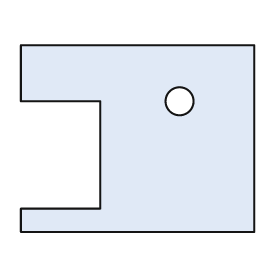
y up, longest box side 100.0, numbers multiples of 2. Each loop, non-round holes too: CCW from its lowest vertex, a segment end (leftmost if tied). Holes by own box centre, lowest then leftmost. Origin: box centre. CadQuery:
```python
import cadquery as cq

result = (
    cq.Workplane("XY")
    .moveTo(-50.0, -40.0)
    .lineTo(50.0, -40.0)
    .lineTo(50.0, 40.0)
    .lineTo(-50.0, 40.0)
    .lineTo(-50.0, 16.0)
    .lineTo(-16.0, 16.0)
    .lineTo(-16.0, -30.0)
    .lineTo(-50.0, -30.0)
    .close()
    .moveTo(18.0, 16.0)
    .circle(6.0)
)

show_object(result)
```